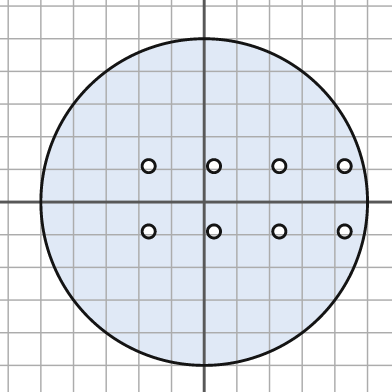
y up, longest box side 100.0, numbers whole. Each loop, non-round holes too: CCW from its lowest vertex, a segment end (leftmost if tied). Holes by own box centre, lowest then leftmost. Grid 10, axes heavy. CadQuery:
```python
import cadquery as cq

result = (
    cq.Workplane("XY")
    .moveTo(0.0, 0.0)
    .circle(50.0)
    .moveTo(-17.0, -9.0)
    .circle(2.0)
    .moveTo(3.0, -9.0)
    .circle(2.0)
    .moveTo(23.0, -9.0)
    .circle(2.0)
    .moveTo(43.0, -9.0)
    .circle(2.0)
    .moveTo(-17.0, 11.0)
    .circle(2.0)
    .moveTo(3.0, 11.0)
    .circle(2.0)
    .moveTo(23.0, 11.0)
    .circle(2.0)
    .moveTo(43.0, 11.0)
    .circle(2.0)
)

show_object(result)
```